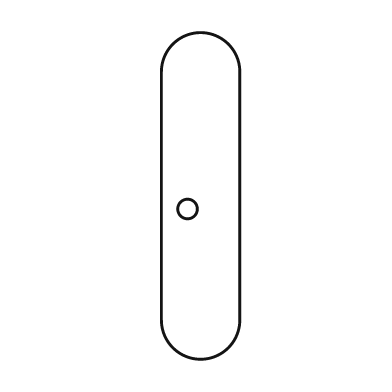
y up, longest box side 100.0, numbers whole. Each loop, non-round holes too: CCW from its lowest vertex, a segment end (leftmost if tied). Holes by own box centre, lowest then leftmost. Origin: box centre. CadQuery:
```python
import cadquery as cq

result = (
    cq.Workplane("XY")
    .moveTo(-12.0, -38.0)
    .threePointArc((0.0, -50.0), (12.0, -38.0))
    .lineTo(12.0, 38.0)
    .threePointArc((0.0, 50.0), (-12.0, 38.0))
    .close()
    .moveTo(-4.0, -4.0)
    .circle(3.0)
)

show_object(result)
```